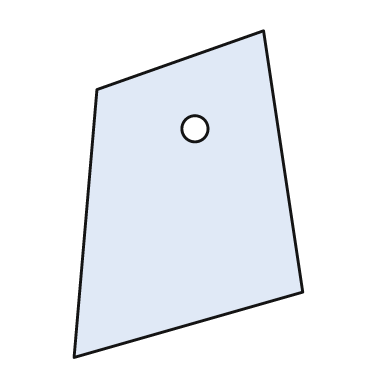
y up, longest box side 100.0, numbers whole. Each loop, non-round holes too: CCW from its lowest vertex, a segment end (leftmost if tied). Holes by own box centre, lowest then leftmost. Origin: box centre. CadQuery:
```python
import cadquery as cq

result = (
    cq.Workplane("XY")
    .moveTo(-35.0, -50.0)
    .lineTo(35.0, -30.0)
    .lineTo(23.0, 50.0)
    .lineTo(-28.0, 32.0)
    .close()
    .moveTo(2.0, 20.0)
    .circle(4.0)
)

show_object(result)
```